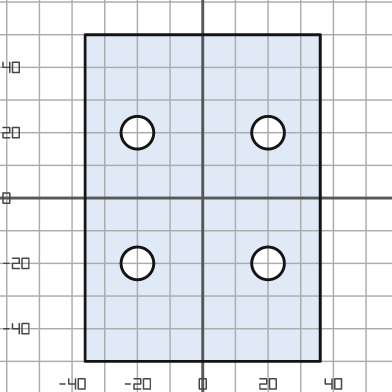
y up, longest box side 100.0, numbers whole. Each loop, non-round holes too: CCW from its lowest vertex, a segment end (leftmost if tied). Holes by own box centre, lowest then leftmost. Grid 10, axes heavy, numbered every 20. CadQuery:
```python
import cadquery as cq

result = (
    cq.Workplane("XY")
    .moveTo(-36.0, -50.0)
    .lineTo(36.0, -50.0)
    .lineTo(36.0, 50.0)
    .lineTo(-36.0, 50.0)
    .close()
    .moveTo(-20.0, -20.0)
    .circle(5.0)
    .moveTo(20.0, -20.0)
    .circle(5.0)
    .moveTo(-20.0, 20.0)
    .circle(5.0)
    .moveTo(20.0, 20.0)
    .circle(5.0)
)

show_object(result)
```